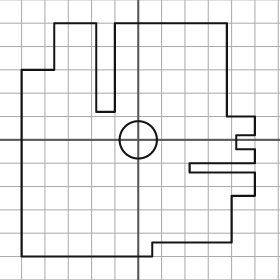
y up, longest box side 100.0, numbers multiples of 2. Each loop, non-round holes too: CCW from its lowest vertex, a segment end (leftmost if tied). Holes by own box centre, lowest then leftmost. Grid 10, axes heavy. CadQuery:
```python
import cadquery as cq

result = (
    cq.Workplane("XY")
    .moveTo(-50.0, -50.0)
    .lineTo(6.0, -50.0)
    .lineTo(6.0, -44.0)
    .lineTo(40.0, -44.0)
    .lineTo(40.0, -24.0)
    .lineTo(50.0, -24.0)
    .lineTo(50.0, -14.0)
    .lineTo(22.0, -14.0)
    .lineTo(22.0, -10.0)
    .lineTo(50.0, -10.0)
    .lineTo(50.0, -4.0)
    .lineTo(42.0, -4.0)
    .lineTo(42.0, 2.0)
    .lineTo(50.0, 2.0)
    .lineTo(50.0, 10.0)
    .lineTo(38.0, 10.0)
    .lineTo(38.0, 50.0)
    .lineTo(-10.0, 50.0)
    .lineTo(-10.0, 12.0)
    .lineTo(-18.0, 12.0)
    .lineTo(-18.0, 50.0)
    .lineTo(-36.0, 50.0)
    .lineTo(-36.0, 30.0)
    .lineTo(-50.0, 30.0)
    .close()
    .moveTo(0.0, 0.0)
    .circle(8.0)
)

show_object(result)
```